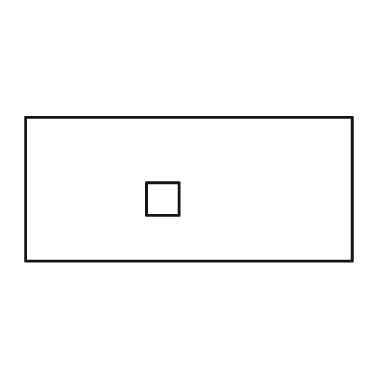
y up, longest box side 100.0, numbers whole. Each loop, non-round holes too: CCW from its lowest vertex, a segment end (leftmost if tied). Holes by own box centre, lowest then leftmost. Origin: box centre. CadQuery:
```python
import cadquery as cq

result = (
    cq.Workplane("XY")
    .moveTo(-50.0, -22.0)
    .lineTo(50.0, -22.0)
    .lineTo(50.0, 22.0)
    .lineTo(-50.0, 22.0)
    .close()
    .moveTo(-13.0, -8.0)
    .lineTo(-3.0, -8.0)
    .lineTo(-3.0, 2.0)
    .lineTo(-13.0, 2.0)
    .close()
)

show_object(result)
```